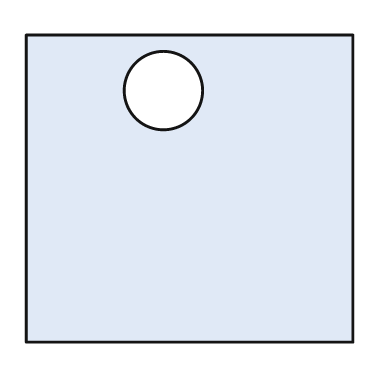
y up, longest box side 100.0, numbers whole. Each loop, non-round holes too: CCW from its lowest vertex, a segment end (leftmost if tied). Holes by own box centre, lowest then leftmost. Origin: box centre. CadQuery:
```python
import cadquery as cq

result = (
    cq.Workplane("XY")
    .moveTo(-50.0, -47.0)
    .lineTo(50.0, -47.0)
    .lineTo(50.0, 47.0)
    .lineTo(-50.0, 47.0)
    .close()
    .moveTo(-8.0, 30.0)
    .circle(12.0)
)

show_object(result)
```